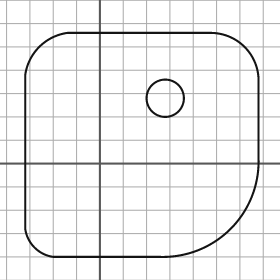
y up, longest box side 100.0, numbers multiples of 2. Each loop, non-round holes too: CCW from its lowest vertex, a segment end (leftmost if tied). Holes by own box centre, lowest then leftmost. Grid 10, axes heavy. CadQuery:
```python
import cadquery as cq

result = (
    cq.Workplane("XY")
    .moveTo(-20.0, -40.0)
    .lineTo(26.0, -40.0)
    .threePointArc((56.0, -28.0), (68.0, 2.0))
    .lineTo(68.0, 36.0)
    .threePointArc((62.0, 50.0), (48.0, 56.0))
    .lineTo(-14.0, 56.0)
    .threePointArc((-26.0, 50.0), (-32.0, 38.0))
    .lineTo(-32.0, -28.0)
    .threePointArc((-28.0, -36.0), (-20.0, -40.0))
    .close()
    .moveTo(28.0, 28.0)
    .circle(8.0)
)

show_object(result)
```